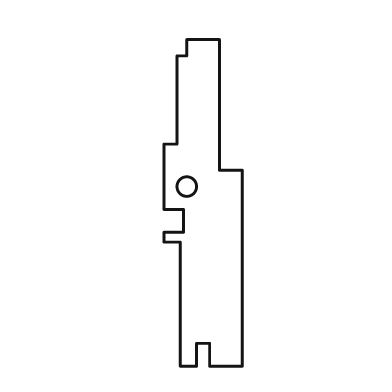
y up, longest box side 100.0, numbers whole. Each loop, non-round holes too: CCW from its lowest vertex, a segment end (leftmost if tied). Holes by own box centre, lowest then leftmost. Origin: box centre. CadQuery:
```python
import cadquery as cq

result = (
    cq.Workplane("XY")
    .moveTo(-7.0, -50.0)
    .lineTo(-2.0, -50.0)
    .lineTo(-2.0, -43.0)
    .lineTo(2.0, -43.0)
    .lineTo(2.0, -50.0)
    .lineTo(12.0, -50.0)
    .lineTo(12.0, 10.0)
    .lineTo(5.0, 10.0)
    .lineTo(5.0, 50.0)
    .lineTo(-5.0, 50.0)
    .lineTo(-5.0, 45.0)
    .lineTo(-8.0, 45.0)
    .lineTo(-8.0, 18.0)
    .lineTo(-12.0, 18.0)
    .lineTo(-12.0, -2.0)
    .lineTo(-6.0, -2.0)
    .lineTo(-6.0, -9.0)
    .lineTo(-12.0, -9.0)
    .lineTo(-12.0, -12.0)
    .lineTo(-7.0, -12.0)
    .close()
    .moveTo(-5.0, 5.0)
    .circle(3.0)
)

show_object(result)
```